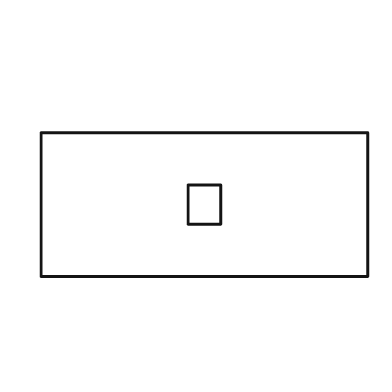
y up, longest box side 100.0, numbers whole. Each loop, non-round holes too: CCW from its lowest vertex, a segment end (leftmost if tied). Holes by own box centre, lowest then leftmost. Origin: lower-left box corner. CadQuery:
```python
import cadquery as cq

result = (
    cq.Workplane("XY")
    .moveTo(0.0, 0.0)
    .lineTo(100.0, 0.0)
    .lineTo(100.0, 44.0)
    .lineTo(0.0, 44.0)
    .close()
    .moveTo(45.0, 16.0)
    .lineTo(55.0, 16.0)
    .lineTo(55.0, 28.0)
    .lineTo(45.0, 28.0)
    .close()
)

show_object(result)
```